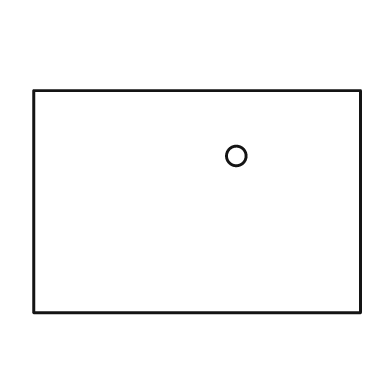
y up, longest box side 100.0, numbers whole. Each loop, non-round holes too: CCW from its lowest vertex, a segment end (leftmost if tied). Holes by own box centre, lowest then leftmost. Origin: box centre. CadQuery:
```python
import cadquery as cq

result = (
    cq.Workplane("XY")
    .moveTo(-50.0, -34.0)
    .lineTo(50.0, -34.0)
    .lineTo(50.0, 34.0)
    .lineTo(-50.0, 34.0)
    .close()
    .moveTo(12.0, 14.0)
    .circle(3.0)
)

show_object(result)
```